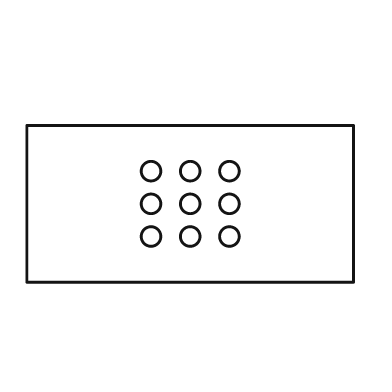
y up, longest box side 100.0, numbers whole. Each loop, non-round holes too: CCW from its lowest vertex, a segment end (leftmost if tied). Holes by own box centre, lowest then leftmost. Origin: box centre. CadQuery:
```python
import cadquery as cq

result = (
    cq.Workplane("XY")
    .moveTo(-50.0, -24.0)
    .lineTo(50.0, -24.0)
    .lineTo(50.0, 24.0)
    .lineTo(-50.0, 24.0)
    .close()
    .moveTo(-12.0, -10.0)
    .circle(3.0)
    .moveTo(0.0, -10.0)
    .circle(3.0)
    .moveTo(12.0, -10.0)
    .circle(3.0)
    .moveTo(-12.0, 0.0)
    .circle(3.0)
    .moveTo(0.0, 0.0)
    .circle(3.0)
    .moveTo(12.0, 0.0)
    .circle(3.0)
    .moveTo(-12.0, 10.0)
    .circle(3.0)
    .moveTo(0.0, 10.0)
    .circle(3.0)
    .moveTo(12.0, 10.0)
    .circle(3.0)
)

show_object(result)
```